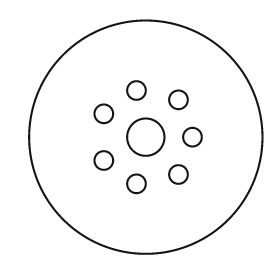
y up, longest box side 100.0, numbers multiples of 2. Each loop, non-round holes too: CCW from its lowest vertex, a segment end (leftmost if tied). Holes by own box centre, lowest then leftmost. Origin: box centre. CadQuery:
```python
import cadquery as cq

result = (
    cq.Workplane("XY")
    .moveTo(0.0, 0.0)
    .circle(50.0)
    .moveTo(-4.0, -20.0)
    .circle(4.0)
    .moveTo(14.0, -16.0)
    .circle(4.0)
    .moveTo(-18.0, -10.0)
    .circle(4.0)
    .moveTo(0.0, 0.0)
    .circle(8.0)
    .moveTo(20.0, 0.0)
    .circle(4.0)
    .moveTo(-18.0, 10.0)
    .circle(4.0)
    .moveTo(14.0, 16.0)
    .circle(4.0)
    .moveTo(-4.0, 20.0)
    .circle(4.0)
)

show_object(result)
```